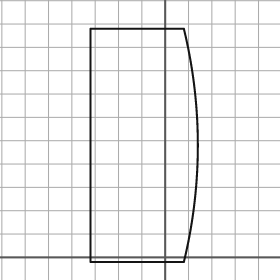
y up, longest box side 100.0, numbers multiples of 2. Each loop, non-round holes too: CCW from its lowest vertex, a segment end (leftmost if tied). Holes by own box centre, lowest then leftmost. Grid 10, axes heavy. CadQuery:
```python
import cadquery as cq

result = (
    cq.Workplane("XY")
    .moveTo(-32.0, -2.0)
    .lineTo(8.0, -2.0)
    .threePointArc((14.0, 48.0), (8.0, 98.0))
    .lineTo(-32.0, 98.0)
    .close()
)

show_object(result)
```